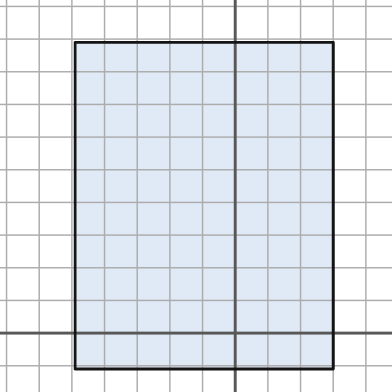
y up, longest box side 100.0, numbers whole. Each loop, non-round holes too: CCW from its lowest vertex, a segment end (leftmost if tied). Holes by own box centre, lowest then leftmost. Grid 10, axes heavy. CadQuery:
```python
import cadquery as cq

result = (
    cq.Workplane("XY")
    .moveTo(-49.0, -11.0)
    .lineTo(30.0, -11.0)
    .lineTo(30.0, 89.0)
    .lineTo(-49.0, 89.0)
    .close()
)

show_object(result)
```